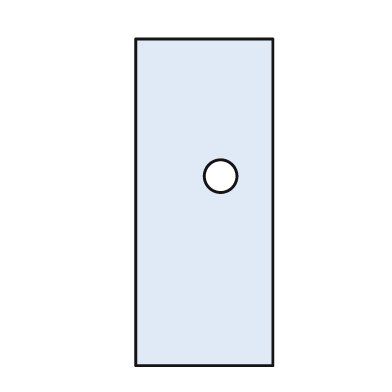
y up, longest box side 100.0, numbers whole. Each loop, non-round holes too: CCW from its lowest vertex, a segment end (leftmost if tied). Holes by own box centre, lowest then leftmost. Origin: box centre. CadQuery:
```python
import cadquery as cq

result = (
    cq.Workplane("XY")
    .moveTo(-21.0, -50.0)
    .lineTo(21.0, -50.0)
    .lineTo(21.0, 50.0)
    .lineTo(-21.0, 50.0)
    .close()
    .moveTo(5.0, 8.0)
    .circle(5.0)
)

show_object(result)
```